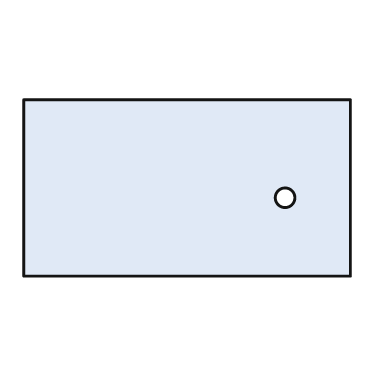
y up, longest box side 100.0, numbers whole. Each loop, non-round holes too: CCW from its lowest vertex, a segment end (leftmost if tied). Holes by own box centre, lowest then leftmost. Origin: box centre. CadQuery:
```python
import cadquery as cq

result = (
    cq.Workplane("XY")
    .moveTo(-50.0, -27.0)
    .lineTo(50.0, -27.0)
    .lineTo(50.0, 27.0)
    .lineTo(-50.0, 27.0)
    .close()
    .moveTo(30.0, -3.0)
    .circle(3.0)
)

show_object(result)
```